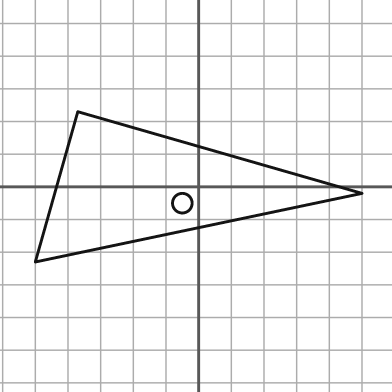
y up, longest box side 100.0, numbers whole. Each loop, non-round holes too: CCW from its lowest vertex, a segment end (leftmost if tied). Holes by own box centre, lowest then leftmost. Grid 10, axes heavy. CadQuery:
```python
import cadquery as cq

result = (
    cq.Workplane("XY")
    .moveTo(-50.0, -23.0)
    .lineTo(50.0, -2.0)
    .lineTo(-37.0, 23.0)
    .close()
    .moveTo(-5.0, -5.0)
    .circle(3.0)
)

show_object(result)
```